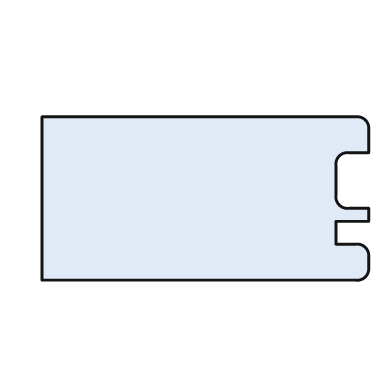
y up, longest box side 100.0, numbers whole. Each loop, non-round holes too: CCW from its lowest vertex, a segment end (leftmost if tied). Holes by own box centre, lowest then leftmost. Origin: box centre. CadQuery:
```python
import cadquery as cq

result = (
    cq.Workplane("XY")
    .moveTo(-50.0, -25.0)
    .lineTo(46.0, -25.0)
    .threePointArc((49.0, -24.0), (50.0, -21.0))
    .lineTo(50.0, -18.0)
    .threePointArc((49.0, -15.0), (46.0, -14.0))
    .lineTo(40.0, -14.0)
    .lineTo(40.0, -7.0)
    .lineTo(50.0, -7.0)
    .lineTo(50.0, -3.0)
    .lineTo(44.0, -3.0)
    .threePointArc((41.0, -2.0), (40.0, 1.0))
    .lineTo(40.0, 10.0)
    .threePointArc((41.0, 13.0), (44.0, 14.0))
    .lineTo(50.0, 14.0)
    .lineTo(50.0, 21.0)
    .threePointArc((49.0, 24.0), (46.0, 25.0))
    .lineTo(-50.0, 25.0)
    .close()
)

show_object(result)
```